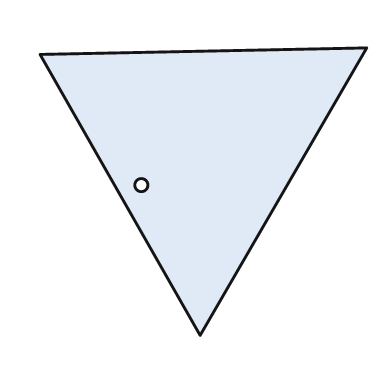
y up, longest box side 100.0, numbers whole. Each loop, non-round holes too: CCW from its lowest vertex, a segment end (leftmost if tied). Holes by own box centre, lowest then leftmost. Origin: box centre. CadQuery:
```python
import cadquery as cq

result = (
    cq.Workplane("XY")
    .moveTo(-1.0, -44.0)
    .lineTo(50.0, 44.0)
    .lineTo(-50.0, 42.0)
    .close()
    .moveTo(-19.0, 2.0)
    .circle(2.0)
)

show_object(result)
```